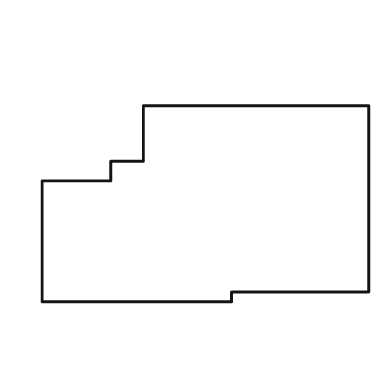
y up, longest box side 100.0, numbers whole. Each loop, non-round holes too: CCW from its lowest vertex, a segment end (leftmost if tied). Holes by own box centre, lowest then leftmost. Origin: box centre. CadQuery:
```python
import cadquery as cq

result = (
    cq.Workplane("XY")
    .moveTo(-50.0, -30.0)
    .lineTo(8.0, -30.0)
    .lineTo(8.0, -27.0)
    .lineTo(50.0, -27.0)
    .lineTo(50.0, 30.0)
    .lineTo(-19.0, 30.0)
    .lineTo(-19.0, 13.0)
    .lineTo(-29.0, 13.0)
    .lineTo(-29.0, 7.0)
    .lineTo(-50.0, 7.0)
    .close()
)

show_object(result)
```